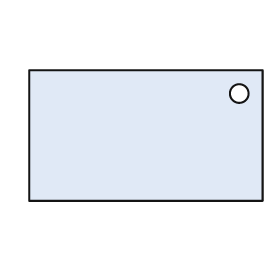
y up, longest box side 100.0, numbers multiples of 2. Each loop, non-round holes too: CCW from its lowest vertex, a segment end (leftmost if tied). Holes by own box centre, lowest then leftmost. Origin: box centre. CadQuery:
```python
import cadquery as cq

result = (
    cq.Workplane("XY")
    .moveTo(-50.0, -28.0)
    .lineTo(50.0, -28.0)
    .lineTo(50.0, 28.0)
    .lineTo(-50.0, 28.0)
    .close()
    .moveTo(40.0, 18.0)
    .circle(4.0)
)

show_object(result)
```